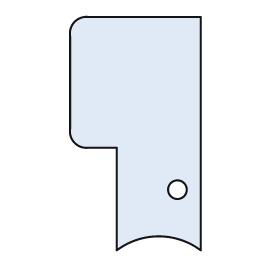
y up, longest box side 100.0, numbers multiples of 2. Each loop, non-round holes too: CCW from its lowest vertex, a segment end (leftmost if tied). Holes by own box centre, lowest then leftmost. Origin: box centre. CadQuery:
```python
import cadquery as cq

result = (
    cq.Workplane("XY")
    .moveTo(-8.0, -50.0)
    .threePointArc((10.0, -44.0), (28.0, -50.0))
    .lineTo(28.0, 50.0)
    .lineTo(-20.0, 50.0)
    .threePointArc((-26.0, 48.0), (-28.0, 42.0))
    .lineTo(-28.0, 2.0)
    .threePointArc((-26.0, -4.0), (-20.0, -6.0))
    .lineTo(-8.0, -6.0)
    .close()
    .moveTo(18.0, -24.0)
    .circle(4.0)
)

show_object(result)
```